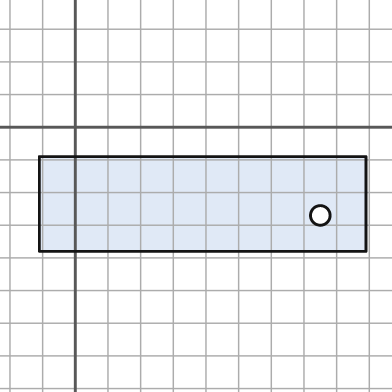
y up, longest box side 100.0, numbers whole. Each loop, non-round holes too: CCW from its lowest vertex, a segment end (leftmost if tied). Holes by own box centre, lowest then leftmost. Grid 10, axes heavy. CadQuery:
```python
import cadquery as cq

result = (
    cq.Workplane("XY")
    .moveTo(-11.0, -38.0)
    .lineTo(89.0, -38.0)
    .lineTo(89.0, -9.0)
    .lineTo(-11.0, -9.0)
    .close()
    .moveTo(75.0, -27.0)
    .circle(3.0)
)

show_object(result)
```